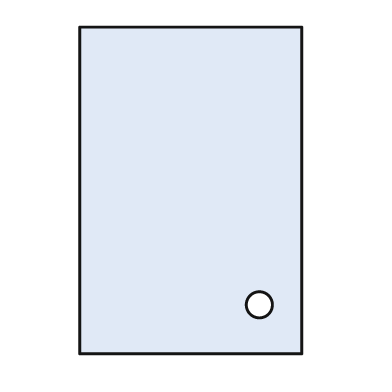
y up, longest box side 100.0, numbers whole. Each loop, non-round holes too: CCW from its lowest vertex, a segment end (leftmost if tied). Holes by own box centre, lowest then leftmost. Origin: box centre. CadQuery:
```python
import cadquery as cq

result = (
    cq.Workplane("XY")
    .moveTo(-34.0, -50.0)
    .lineTo(34.0, -50.0)
    .lineTo(34.0, 50.0)
    .lineTo(-34.0, 50.0)
    .close()
    .moveTo(21.0, -35.0)
    .circle(4.0)
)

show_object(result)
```